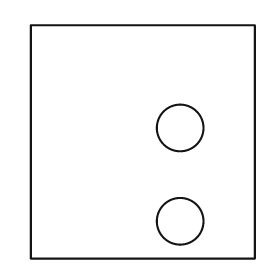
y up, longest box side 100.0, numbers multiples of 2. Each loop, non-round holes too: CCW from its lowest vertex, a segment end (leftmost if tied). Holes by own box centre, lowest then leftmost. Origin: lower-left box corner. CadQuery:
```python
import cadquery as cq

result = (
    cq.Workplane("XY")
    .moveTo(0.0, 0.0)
    .lineTo(96.0, 0.0)
    .lineTo(96.0, 100.0)
    .lineTo(0.0, 100.0)
    .close()
    .moveTo(64.0, 16.0)
    .circle(10.0)
    .moveTo(64.0, 56.0)
    .circle(10.0)
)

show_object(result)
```